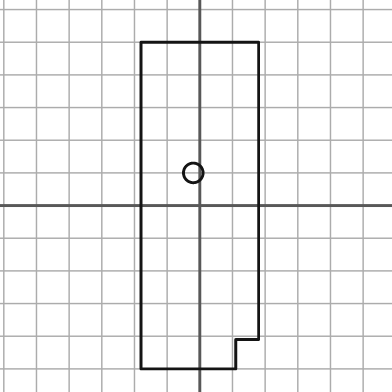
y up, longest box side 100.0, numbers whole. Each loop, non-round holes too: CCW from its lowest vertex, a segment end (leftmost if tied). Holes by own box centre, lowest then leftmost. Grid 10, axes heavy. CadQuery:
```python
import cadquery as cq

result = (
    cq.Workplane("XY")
    .moveTo(-18.0, -50.0)
    .lineTo(11.0, -50.0)
    .lineTo(11.0, -41.0)
    .lineTo(18.0, -41.0)
    .lineTo(18.0, 50.0)
    .lineTo(-18.0, 50.0)
    .close()
    .moveTo(-2.0, 10.0)
    .circle(3.0)
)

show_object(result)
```